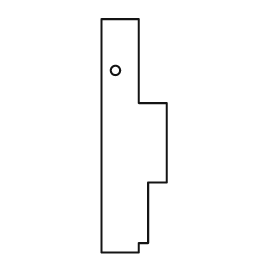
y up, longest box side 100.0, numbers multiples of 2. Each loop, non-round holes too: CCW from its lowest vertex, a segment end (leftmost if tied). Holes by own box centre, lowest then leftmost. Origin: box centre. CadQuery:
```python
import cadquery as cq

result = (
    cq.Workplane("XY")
    .moveTo(-14.0, -50.0)
    .lineTo(2.0, -50.0)
    .lineTo(2.0, -46.0)
    .lineTo(6.0, -46.0)
    .lineTo(6.0, -20.0)
    .lineTo(14.0, -20.0)
    .lineTo(14.0, 14.0)
    .lineTo(2.0, 14.0)
    .lineTo(2.0, 50.0)
    .lineTo(-14.0, 50.0)
    .close()
    .moveTo(-8.0, 28.0)
    .circle(2.0)
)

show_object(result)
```